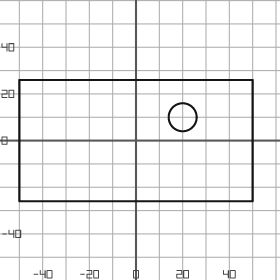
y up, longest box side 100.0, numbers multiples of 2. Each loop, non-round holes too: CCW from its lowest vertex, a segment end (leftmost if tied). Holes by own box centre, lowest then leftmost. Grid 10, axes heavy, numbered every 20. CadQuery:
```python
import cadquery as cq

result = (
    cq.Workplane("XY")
    .moveTo(-50.0, -26.0)
    .lineTo(50.0, -26.0)
    .lineTo(50.0, 26.0)
    .lineTo(-50.0, 26.0)
    .close()
    .moveTo(20.0, 10.0)
    .circle(6.0)
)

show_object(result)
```